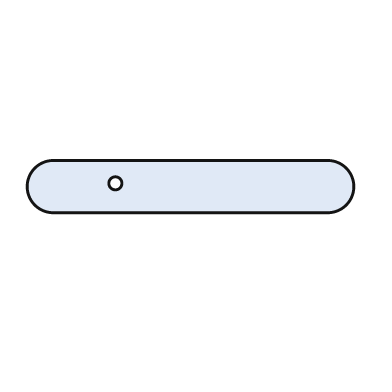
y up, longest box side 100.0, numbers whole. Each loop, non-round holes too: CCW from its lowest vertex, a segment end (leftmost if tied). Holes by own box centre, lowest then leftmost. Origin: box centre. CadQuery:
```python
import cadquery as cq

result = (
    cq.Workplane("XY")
    .moveTo(-42.0, -8.0)
    .lineTo(42.0, -8.0)
    .threePointArc((50.0, 0.0), (42.0, 8.0))
    .lineTo(-42.0, 8.0)
    .threePointArc((-50.0, 0.0), (-42.0, -8.0))
    .close()
    .moveTo(-23.0, 1.0)
    .circle(2.0)
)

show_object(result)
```